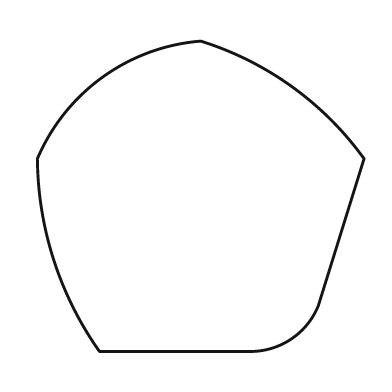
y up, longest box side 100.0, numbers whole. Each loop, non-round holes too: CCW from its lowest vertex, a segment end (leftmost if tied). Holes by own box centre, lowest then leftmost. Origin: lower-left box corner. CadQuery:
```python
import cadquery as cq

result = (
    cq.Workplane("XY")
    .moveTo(19.0, 0.0)
    .lineTo(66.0, 0.0)
    .threePointArc((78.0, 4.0), (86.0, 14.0))
    .lineTo(100.0, 59.0)
    .threePointArc((78.0, 81.0), (50.0, 95.0))
    .threePointArc((20.0, 84.0), (0.0, 59.0))
    .threePointArc((5.0, 28.0), (19.0, 0.0))
    .close()
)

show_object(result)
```